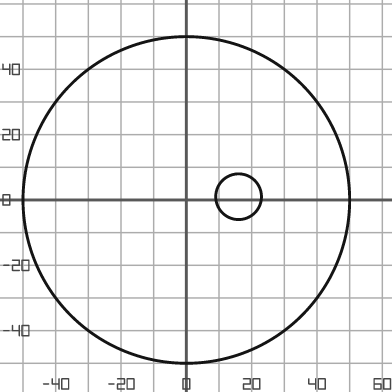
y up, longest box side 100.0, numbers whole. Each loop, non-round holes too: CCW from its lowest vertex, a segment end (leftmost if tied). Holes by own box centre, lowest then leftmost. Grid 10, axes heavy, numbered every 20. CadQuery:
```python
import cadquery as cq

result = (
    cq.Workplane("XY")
    .moveTo(0.0, 0.0)
    .circle(50.0)
    .moveTo(16.0, 1.0)
    .circle(7.0)
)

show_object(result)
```